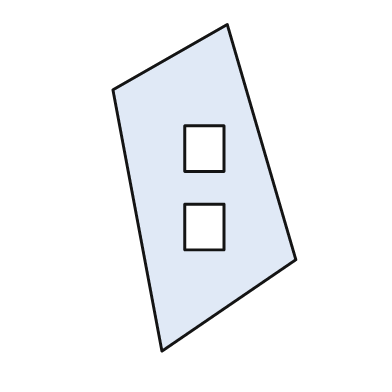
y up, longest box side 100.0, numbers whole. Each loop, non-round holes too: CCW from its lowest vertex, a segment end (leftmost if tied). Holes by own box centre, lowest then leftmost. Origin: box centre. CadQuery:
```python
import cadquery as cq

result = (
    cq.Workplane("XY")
    .moveTo(-13.0, -50.0)
    .lineTo(28.0, -22.0)
    .lineTo(7.0, 50.0)
    .lineTo(-28.0, 30.0)
    .close()
    .moveTo(-6.0, -19.0)
    .lineTo(6.0, -19.0)
    .lineTo(6.0, -5.0)
    .lineTo(-6.0, -5.0)
    .close()
    .moveTo(-6.0, 5.0)
    .lineTo(6.0, 5.0)
    .lineTo(6.0, 19.0)
    .lineTo(-6.0, 19.0)
    .close()
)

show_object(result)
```